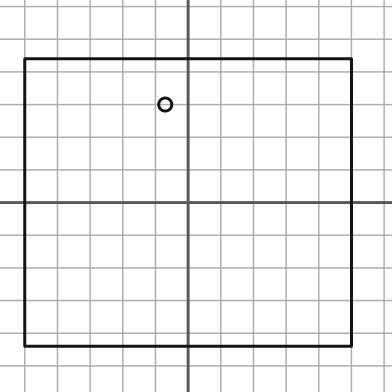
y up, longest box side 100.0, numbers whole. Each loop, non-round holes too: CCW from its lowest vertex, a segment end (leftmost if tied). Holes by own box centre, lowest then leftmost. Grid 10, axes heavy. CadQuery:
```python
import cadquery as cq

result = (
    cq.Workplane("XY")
    .moveTo(-50.0, -44.0)
    .lineTo(50.0, -44.0)
    .lineTo(50.0, 44.0)
    .lineTo(-50.0, 44.0)
    .close()
    .moveTo(-7.0, 30.0)
    .circle(2.0)
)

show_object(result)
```